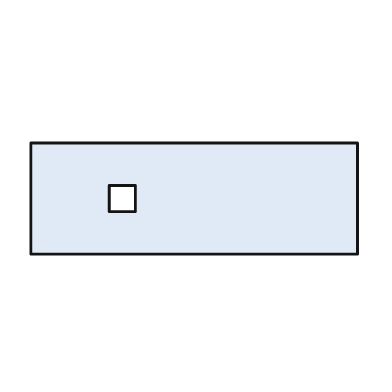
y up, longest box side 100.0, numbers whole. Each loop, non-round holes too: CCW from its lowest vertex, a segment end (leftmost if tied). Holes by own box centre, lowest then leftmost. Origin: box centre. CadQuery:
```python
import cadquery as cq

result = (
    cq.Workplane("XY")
    .moveTo(-50.0, -17.0)
    .lineTo(50.0, -17.0)
    .lineTo(50.0, 17.0)
    .lineTo(-50.0, 17.0)
    .close()
    .moveTo(-26.0, -4.0)
    .lineTo(-18.0, -4.0)
    .lineTo(-18.0, 4.0)
    .lineTo(-26.0, 4.0)
    .close()
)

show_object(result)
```